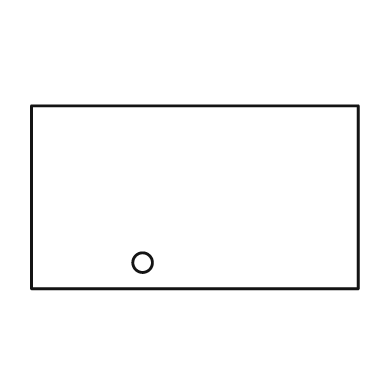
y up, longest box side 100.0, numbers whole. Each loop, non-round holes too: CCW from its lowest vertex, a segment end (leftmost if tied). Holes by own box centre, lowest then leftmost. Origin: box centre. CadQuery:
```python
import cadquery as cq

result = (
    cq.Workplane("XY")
    .moveTo(-50.0, -28.0)
    .lineTo(50.0, -28.0)
    .lineTo(50.0, 28.0)
    .lineTo(-50.0, 28.0)
    .close()
    .moveTo(-16.0, -20.0)
    .circle(3.0)
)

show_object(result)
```